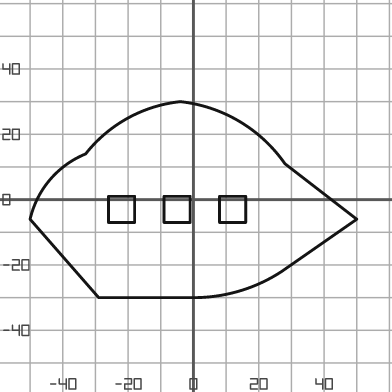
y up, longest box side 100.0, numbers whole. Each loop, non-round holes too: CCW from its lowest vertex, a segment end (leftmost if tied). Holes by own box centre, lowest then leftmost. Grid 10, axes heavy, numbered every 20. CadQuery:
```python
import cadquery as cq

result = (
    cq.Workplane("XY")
    .moveTo(-29.0, -30.0)
    .lineTo(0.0, -30.0)
    .threePointArc((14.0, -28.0), (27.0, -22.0))
    .lineTo(50.0, -6.0)
    .lineTo(28.0, 11.0)
    .threePointArc((14.0, 24.0), (-4.0, 30.0))
    .threePointArc((-20.0, 25.0), (-33.0, 14.0))
    .threePointArc((-44.0, 6.0), (-50.0, -6.0))
    .close()
    .moveTo(-26.0, -7.0)
    .lineTo(-18.0, -7.0)
    .lineTo(-18.0, 1.0)
    .lineTo(-26.0, 1.0)
    .close()
    .moveTo(-9.0, -7.0)
    .lineTo(-1.0, -7.0)
    .lineTo(-1.0, 1.0)
    .lineTo(-9.0, 1.0)
    .close()
    .moveTo(8.0, -7.0)
    .lineTo(16.0, -7.0)
    .lineTo(16.0, 1.0)
    .lineTo(8.0, 1.0)
    .close()
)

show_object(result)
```